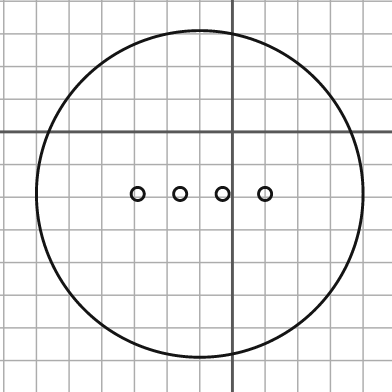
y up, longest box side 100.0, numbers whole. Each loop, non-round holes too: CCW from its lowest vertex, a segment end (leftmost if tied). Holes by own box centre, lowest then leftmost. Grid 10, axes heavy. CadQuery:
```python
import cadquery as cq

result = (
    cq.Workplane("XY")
    .moveTo(-10.0, -19.0)
    .circle(50.0)
    .moveTo(-29.0, -19.0)
    .circle(2.0)
    .moveTo(-16.0, -19.0)
    .circle(2.0)
    .moveTo(-3.0, -19.0)
    .circle(2.0)
    .moveTo(10.0, -19.0)
    .circle(2.0)
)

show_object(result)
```